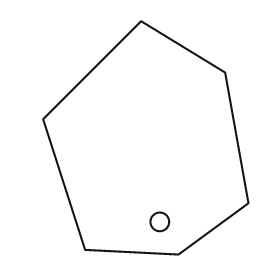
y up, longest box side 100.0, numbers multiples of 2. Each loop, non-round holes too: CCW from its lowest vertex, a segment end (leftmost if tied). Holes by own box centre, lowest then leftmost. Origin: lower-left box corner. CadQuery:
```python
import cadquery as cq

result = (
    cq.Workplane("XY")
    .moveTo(58.0, 0.0)
    .lineTo(88.0, 22.0)
    .lineTo(78.0, 78.0)
    .lineTo(42.0, 100.0)
    .lineTo(0.0, 58.0)
    .lineTo(18.0, 2.0)
    .close()
    .moveTo(50.0, 14.0)
    .circle(4.0)
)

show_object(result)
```